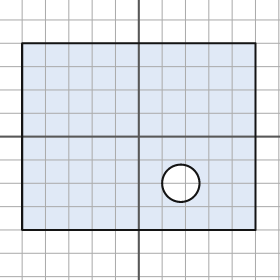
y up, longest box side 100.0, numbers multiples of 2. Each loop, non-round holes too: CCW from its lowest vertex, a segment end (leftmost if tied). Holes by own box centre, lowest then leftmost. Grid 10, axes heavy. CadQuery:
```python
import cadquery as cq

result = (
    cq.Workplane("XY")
    .moveTo(-50.0, -40.0)
    .lineTo(50.0, -40.0)
    .lineTo(50.0, 40.0)
    .lineTo(-50.0, 40.0)
    .close()
    .moveTo(18.0, -20.0)
    .circle(8.0)
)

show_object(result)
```